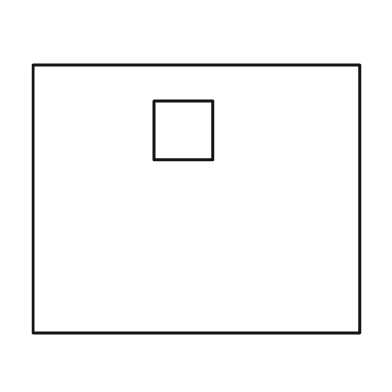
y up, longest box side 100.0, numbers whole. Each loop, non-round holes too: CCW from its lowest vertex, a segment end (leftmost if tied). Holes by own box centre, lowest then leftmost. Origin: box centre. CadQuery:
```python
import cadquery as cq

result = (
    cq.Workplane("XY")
    .moveTo(-50.0, -41.0)
    .lineTo(50.0, -41.0)
    .lineTo(50.0, 41.0)
    .lineTo(-50.0, 41.0)
    .close()
    .moveTo(-13.0, 12.0)
    .lineTo(5.0, 12.0)
    .lineTo(5.0, 30.0)
    .lineTo(-13.0, 30.0)
    .close()
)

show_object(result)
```